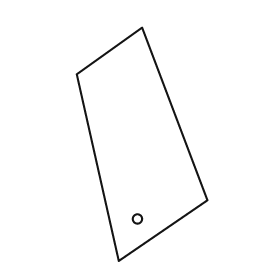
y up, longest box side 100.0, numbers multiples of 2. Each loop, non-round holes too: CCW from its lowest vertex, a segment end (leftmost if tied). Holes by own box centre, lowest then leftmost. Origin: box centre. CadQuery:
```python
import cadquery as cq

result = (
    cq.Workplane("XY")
    .moveTo(-10.0, -50.0)
    .lineTo(28.0, -24.0)
    .lineTo(0.0, 50.0)
    .lineTo(-28.0, 30.0)
    .close()
    .moveTo(-2.0, -32.0)
    .circle(2.0)
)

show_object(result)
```